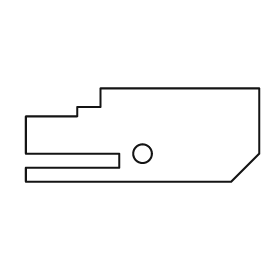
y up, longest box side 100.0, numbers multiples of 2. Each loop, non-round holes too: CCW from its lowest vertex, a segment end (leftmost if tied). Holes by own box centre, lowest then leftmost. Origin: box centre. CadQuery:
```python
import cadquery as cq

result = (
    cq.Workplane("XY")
    .moveTo(-50.0, -20.0)
    .lineTo(38.0, -20.0)
    .lineTo(50.0, -8.0)
    .lineTo(50.0, 20.0)
    .lineTo(-18.0, 20.0)
    .lineTo(-18.0, 12.0)
    .lineTo(-28.0, 12.0)
    .lineTo(-28.0, 8.0)
    .lineTo(-50.0, 8.0)
    .lineTo(-50.0, -8.0)
    .lineTo(-10.0, -8.0)
    .lineTo(-10.0, -14.0)
    .lineTo(-50.0, -14.0)
    .close()
    .moveTo(0.0, -8.0)
    .circle(4.0)
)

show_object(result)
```